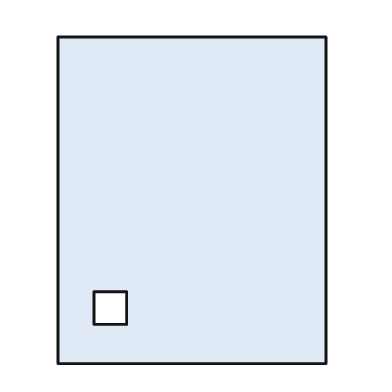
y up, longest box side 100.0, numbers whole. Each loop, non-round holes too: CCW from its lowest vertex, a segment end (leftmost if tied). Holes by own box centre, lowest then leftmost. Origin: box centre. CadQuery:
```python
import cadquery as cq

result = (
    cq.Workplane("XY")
    .moveTo(-41.0, -50.0)
    .lineTo(41.0, -50.0)
    .lineTo(41.0, 50.0)
    .lineTo(-41.0, 50.0)
    .close()
    .moveTo(-30.0, -38.0)
    .lineTo(-20.0, -38.0)
    .lineTo(-20.0, -28.0)
    .lineTo(-30.0, -28.0)
    .close()
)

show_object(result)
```